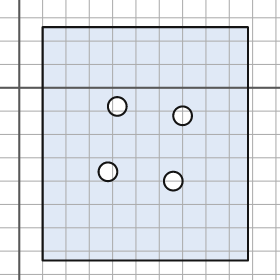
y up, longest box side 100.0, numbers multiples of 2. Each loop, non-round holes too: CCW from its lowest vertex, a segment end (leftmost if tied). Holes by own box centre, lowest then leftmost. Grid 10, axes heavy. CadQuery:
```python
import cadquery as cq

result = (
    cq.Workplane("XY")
    .moveTo(10.0, -74.0)
    .lineTo(98.0, -74.0)
    .lineTo(98.0, 26.0)
    .lineTo(10.0, 26.0)
    .close()
    .moveTo(66.0, -40.0)
    .circle(4.0)
    .moveTo(38.0, -36.0)
    .circle(4.0)
    .moveTo(70.0, -12.0)
    .circle(4.0)
    .moveTo(42.0, -8.0)
    .circle(4.0)
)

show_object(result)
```